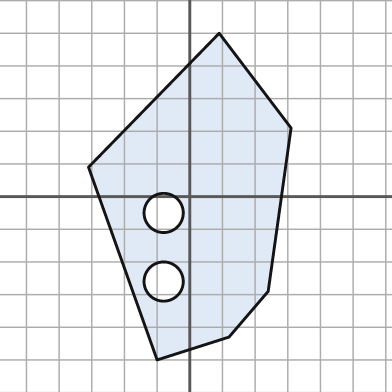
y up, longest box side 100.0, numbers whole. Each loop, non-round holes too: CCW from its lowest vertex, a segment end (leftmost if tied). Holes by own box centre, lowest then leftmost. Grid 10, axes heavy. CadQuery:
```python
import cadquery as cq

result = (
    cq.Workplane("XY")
    .moveTo(-10.0, -50.0)
    .lineTo(12.0, -43.0)
    .lineTo(24.0, -29.0)
    .lineTo(31.0, 21.0)
    .lineTo(9.0, 50.0)
    .lineTo(-31.0, 9.0)
    .close()
    .moveTo(-8.0, -26.0)
    .circle(6.0)
    .moveTo(-8.0, -5.0)
    .circle(6.0)
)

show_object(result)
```